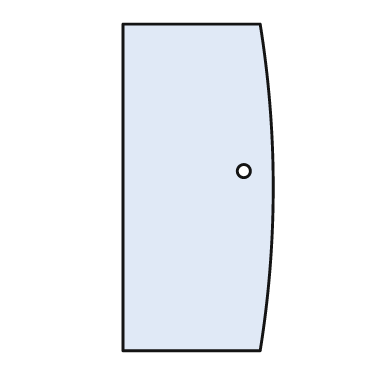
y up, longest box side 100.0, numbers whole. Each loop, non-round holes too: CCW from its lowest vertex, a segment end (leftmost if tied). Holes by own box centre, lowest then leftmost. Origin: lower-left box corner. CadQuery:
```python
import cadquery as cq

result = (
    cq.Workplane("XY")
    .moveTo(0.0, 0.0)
    .lineTo(42.0, 0.0)
    .threePointArc((46.0, 50.0), (42.0, 100.0))
    .lineTo(0.0, 100.0)
    .close()
    .moveTo(37.0, 55.0)
    .circle(2.0)
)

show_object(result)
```